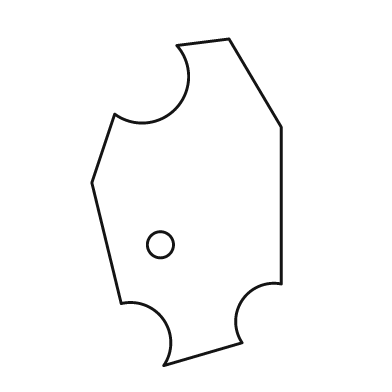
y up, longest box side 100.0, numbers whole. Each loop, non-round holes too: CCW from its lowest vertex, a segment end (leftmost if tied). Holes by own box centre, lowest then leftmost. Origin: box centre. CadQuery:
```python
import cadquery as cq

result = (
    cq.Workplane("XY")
    .moveTo(-7.0, -50.0)
    .lineTo(17.0, -43.0)
    .threePointArc((17.0, -30.0), (29.0, -25.0))
    .lineTo(29.0, 23.0)
    .lineTo(13.0, 50.0)
    .lineTo(-3.0, 48.0)
    .threePointArc((-3.0, 29.0), (-22.0, 27.0))
    .lineTo(-29.0, 6.0)
    .lineTo(-20.0, -31.0)
    .threePointArc((-7.0, -36.0), (-7.0, -50.0))
    .close()
    .moveTo(-8.0, -13.0)
    .circle(4.0)
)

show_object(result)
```